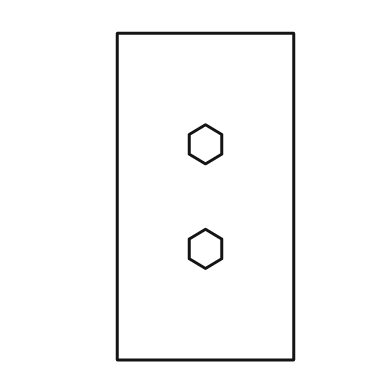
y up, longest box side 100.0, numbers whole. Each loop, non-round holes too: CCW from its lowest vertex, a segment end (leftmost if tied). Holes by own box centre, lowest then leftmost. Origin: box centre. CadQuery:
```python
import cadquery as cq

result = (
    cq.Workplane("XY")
    .moveTo(-27.0, -50.0)
    .lineTo(27.0, -50.0)
    .lineTo(27.0, 50.0)
    .lineTo(-27.0, 50.0)
    .close()
    .moveTo(0.0, -22.0)
    .lineTo(5.0, -19.0)
    .lineTo(5.0, -13.0)
    .lineTo(0.0, -10.0)
    .lineTo(-5.0, -13.0)
    .lineTo(-5.0, -19.0)
    .close()
    .moveTo(0.0, 10.0)
    .lineTo(5.0, 13.0)
    .lineTo(5.0, 19.0)
    .lineTo(0.0, 22.0)
    .lineTo(-5.0, 19.0)
    .lineTo(-5.0, 13.0)
    .close()
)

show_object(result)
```